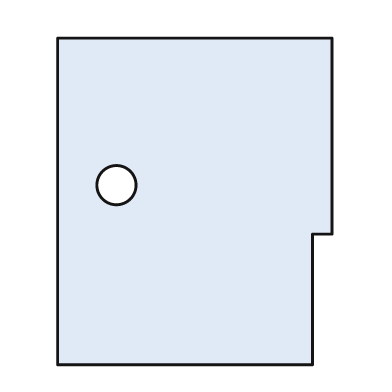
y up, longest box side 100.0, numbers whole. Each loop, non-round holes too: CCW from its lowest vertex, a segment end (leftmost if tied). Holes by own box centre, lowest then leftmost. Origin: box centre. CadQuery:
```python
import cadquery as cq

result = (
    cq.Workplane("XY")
    .moveTo(-42.0, -50.0)
    .lineTo(36.0, -50.0)
    .lineTo(36.0, -10.0)
    .lineTo(42.0, -10.0)
    .lineTo(42.0, 50.0)
    .lineTo(-42.0, 50.0)
    .close()
    .moveTo(-24.0, 5.0)
    .circle(6.0)
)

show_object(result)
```